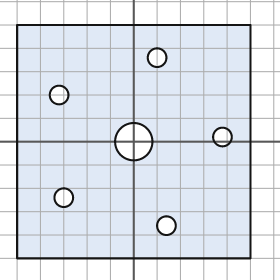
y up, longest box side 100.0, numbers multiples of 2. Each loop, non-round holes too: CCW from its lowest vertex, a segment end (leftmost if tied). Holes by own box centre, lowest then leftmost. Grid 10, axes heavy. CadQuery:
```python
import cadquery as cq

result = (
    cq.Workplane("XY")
    .moveTo(-50.0, -50.0)
    .lineTo(50.0, -50.0)
    .lineTo(50.0, 50.0)
    .lineTo(-50.0, 50.0)
    .close()
    .moveTo(14.0, -36.0)
    .circle(4.0)
    .moveTo(-30.0, -24.0)
    .circle(4.0)
    .moveTo(0.0, 0.0)
    .circle(8.0)
    .moveTo(38.0, 2.0)
    .circle(4.0)
    .moveTo(-32.0, 20.0)
    .circle(4.0)
    .moveTo(10.0, 36.0)
    .circle(4.0)
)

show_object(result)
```